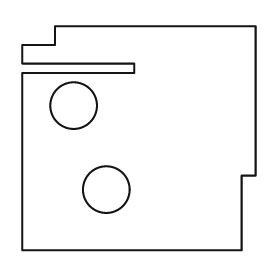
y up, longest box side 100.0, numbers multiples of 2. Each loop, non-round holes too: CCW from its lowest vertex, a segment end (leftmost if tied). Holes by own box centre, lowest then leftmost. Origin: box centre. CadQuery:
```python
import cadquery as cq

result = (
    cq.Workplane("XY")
    .moveTo(-50.0, -48.0)
    .lineTo(44.0, -48.0)
    .lineTo(44.0, -16.0)
    .lineTo(50.0, -16.0)
    .lineTo(50.0, 48.0)
    .lineTo(-36.0, 48.0)
    .lineTo(-36.0, 40.0)
    .lineTo(-50.0, 40.0)
    .lineTo(-50.0, 32.0)
    .lineTo(-2.0, 32.0)
    .lineTo(-2.0, 28.0)
    .lineTo(-50.0, 28.0)
    .close()
    .moveTo(-14.0, -22.0)
    .circle(10.0)
    .moveTo(-28.0, 14.0)
    .circle(10.0)
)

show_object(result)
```